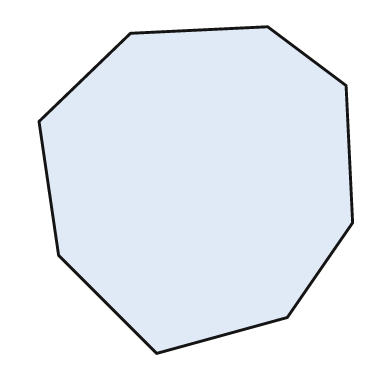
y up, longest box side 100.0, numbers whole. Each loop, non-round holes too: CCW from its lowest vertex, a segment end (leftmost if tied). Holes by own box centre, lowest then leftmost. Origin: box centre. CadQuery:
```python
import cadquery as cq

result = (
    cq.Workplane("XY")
    .moveTo(-12.0, -50.0)
    .lineTo(28.0, -39.0)
    .lineTo(48.0, -10.0)
    .lineTo(46.0, 32.0)
    .lineTo(22.0, 50.0)
    .lineTo(-20.0, 48.0)
    .lineTo(-48.0, 21.0)
    .lineTo(-42.0, -20.0)
    .close()
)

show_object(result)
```